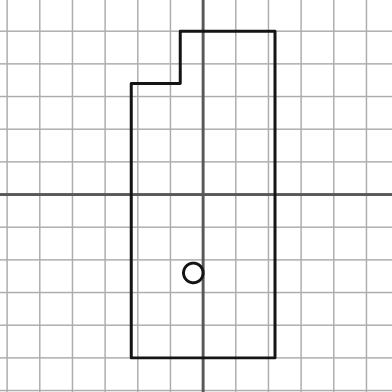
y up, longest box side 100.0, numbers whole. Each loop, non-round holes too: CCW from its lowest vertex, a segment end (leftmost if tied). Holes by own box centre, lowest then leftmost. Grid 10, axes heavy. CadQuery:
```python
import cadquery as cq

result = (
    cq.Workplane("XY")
    .moveTo(-22.0, -50.0)
    .lineTo(22.0, -50.0)
    .lineTo(22.0, 50.0)
    .lineTo(-7.0, 50.0)
    .lineTo(-7.0, 34.0)
    .lineTo(-22.0, 34.0)
    .close()
    .moveTo(-3.0, -24.0)
    .circle(3.0)
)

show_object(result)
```